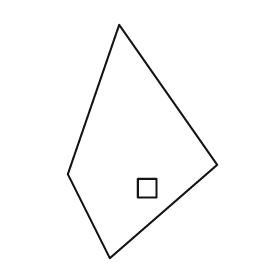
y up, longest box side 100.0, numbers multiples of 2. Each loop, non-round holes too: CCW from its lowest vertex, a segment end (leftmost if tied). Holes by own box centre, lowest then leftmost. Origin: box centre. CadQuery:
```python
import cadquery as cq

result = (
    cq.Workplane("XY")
    .moveTo(-14.0, -50.0)
    .lineTo(32.0, -10.0)
    .lineTo(-10.0, 50.0)
    .lineTo(-32.0, -14.0)
    .close()
    .moveTo(-2.0, -24.0)
    .lineTo(6.0, -24.0)
    .lineTo(6.0, -16.0)
    .lineTo(-2.0, -16.0)
    .close()
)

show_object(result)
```